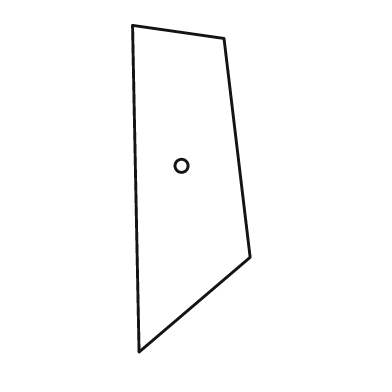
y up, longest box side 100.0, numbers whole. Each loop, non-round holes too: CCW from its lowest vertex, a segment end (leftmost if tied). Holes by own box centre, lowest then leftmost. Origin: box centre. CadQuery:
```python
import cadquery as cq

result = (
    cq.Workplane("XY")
    .moveTo(-16.0, -50.0)
    .lineTo(18.0, -21.0)
    .lineTo(10.0, 46.0)
    .lineTo(-18.0, 50.0)
    .close()
    .moveTo(-3.0, 7.0)
    .circle(2.0)
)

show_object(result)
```